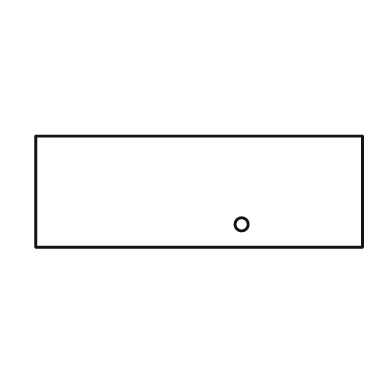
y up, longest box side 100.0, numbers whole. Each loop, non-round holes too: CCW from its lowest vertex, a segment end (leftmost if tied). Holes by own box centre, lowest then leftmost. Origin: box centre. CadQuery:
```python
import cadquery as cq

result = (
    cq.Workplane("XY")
    .moveTo(-50.0, -17.0)
    .lineTo(50.0, -17.0)
    .lineTo(50.0, 17.0)
    .lineTo(-50.0, 17.0)
    .close()
    .moveTo(13.0, -10.0)
    .circle(2.0)
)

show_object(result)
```